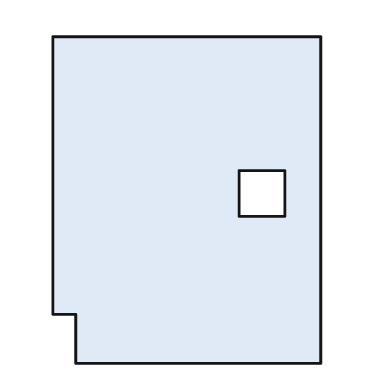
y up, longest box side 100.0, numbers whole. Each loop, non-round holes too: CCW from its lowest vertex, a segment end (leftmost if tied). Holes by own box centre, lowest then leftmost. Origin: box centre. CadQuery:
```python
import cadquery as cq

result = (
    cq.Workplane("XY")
    .moveTo(-34.0, -50.0)
    .lineTo(41.0, -50.0)
    .lineTo(41.0, 50.0)
    .lineTo(-41.0, 50.0)
    .lineTo(-41.0, -35.0)
    .lineTo(-34.0, -35.0)
    .close()
    .moveTo(16.0, -5.0)
    .lineTo(30.0, -5.0)
    .lineTo(30.0, 9.0)
    .lineTo(16.0, 9.0)
    .close()
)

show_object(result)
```